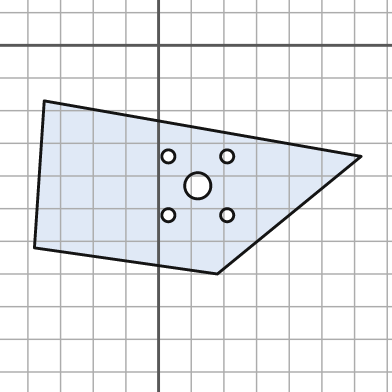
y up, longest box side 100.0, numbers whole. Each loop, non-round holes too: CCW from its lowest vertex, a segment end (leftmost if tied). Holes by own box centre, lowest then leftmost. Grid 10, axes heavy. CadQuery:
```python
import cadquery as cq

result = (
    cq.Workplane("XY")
    .moveTo(18.0, -70.0)
    .lineTo(62.0, -34.0)
    .lineTo(-35.0, -17.0)
    .lineTo(-38.0, -62.0)
    .close()
    .moveTo(3.0, -52.0)
    .circle(2.0)
    .moveTo(21.0, -52.0)
    .circle(2.0)
    .moveTo(12.0, -43.0)
    .circle(4.0)
    .moveTo(3.0, -34.0)
    .circle(2.0)
    .moveTo(21.0, -34.0)
    .circle(2.0)
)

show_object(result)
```